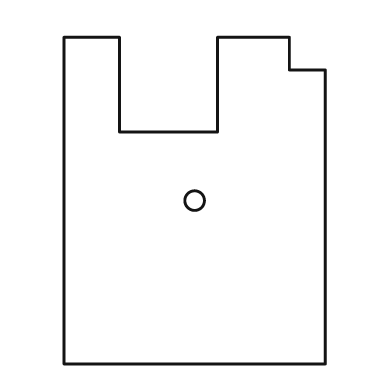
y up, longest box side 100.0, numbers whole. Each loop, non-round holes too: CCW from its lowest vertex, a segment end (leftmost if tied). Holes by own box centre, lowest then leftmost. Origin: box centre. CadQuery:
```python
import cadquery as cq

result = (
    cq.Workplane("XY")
    .moveTo(-40.0, -50.0)
    .lineTo(40.0, -50.0)
    .lineTo(40.0, 40.0)
    .lineTo(29.0, 40.0)
    .lineTo(29.0, 50.0)
    .lineTo(7.0, 50.0)
    .lineTo(7.0, 21.0)
    .lineTo(-23.0, 21.0)
    .lineTo(-23.0, 50.0)
    .lineTo(-40.0, 50.0)
    .close()
    .moveTo(0.0, 0.0)
    .circle(3.0)
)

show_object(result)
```